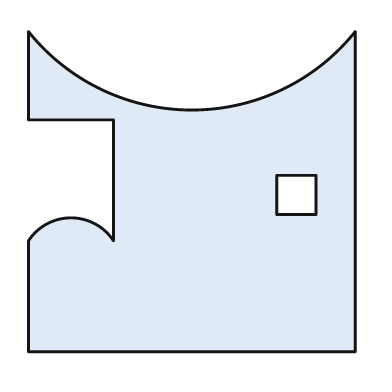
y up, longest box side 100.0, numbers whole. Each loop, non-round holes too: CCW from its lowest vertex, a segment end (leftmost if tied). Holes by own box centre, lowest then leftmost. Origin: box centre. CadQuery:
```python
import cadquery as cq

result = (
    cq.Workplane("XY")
    .moveTo(-50.0, -49.0)
    .lineTo(50.0, -49.0)
    .lineTo(50.0, 49.0)
    .threePointArc((0.0, 25.0), (-50.0, 49.0))
    .lineTo(-50.0, 22.0)
    .lineTo(-24.0, 22.0)
    .lineTo(-24.0, -15.0)
    .threePointArc((-37.0, -8.0), (-50.0, -15.0))
    .close()
    .moveTo(26.0, -7.0)
    .lineTo(38.0, -7.0)
    .lineTo(38.0, 5.0)
    .lineTo(26.0, 5.0)
    .close()
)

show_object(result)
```